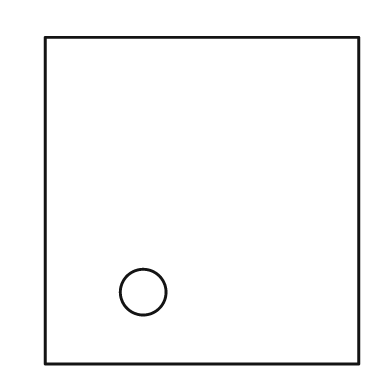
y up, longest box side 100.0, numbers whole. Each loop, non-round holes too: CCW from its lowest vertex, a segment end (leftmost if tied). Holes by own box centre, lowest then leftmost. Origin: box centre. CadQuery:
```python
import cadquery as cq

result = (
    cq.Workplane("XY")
    .moveTo(-48.0, -50.0)
    .lineTo(48.0, -50.0)
    .lineTo(48.0, 50.0)
    .lineTo(-48.0, 50.0)
    .close()
    .moveTo(-18.0, -28.0)
    .circle(7.0)
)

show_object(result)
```